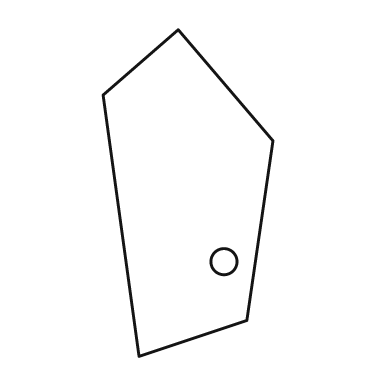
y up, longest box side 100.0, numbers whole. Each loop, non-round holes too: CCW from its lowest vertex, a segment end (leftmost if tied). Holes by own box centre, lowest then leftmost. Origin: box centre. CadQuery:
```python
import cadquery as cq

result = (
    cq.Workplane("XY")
    .moveTo(-15.0, -50.0)
    .lineTo(18.0, -39.0)
    .lineTo(26.0, 16.0)
    .lineTo(-3.0, 50.0)
    .lineTo(-26.0, 30.0)
    .close()
    .moveTo(11.0, -21.0)
    .circle(4.0)
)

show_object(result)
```